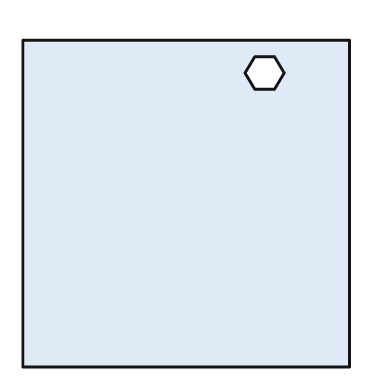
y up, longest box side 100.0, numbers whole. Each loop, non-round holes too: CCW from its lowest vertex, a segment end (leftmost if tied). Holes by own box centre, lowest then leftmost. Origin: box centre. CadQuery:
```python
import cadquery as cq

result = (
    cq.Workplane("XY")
    .moveTo(-50.0, -50.0)
    .lineTo(50.0, -50.0)
    .lineTo(50.0, 50.0)
    .lineTo(-50.0, 50.0)
    .close()
    .moveTo(21.0, 35.0)
    .lineTo(27.0, 35.0)
    .lineTo(30.0, 40.0)
    .lineTo(27.0, 45.0)
    .lineTo(21.0, 45.0)
    .lineTo(18.0, 40.0)
    .close()
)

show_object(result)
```